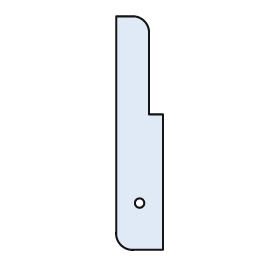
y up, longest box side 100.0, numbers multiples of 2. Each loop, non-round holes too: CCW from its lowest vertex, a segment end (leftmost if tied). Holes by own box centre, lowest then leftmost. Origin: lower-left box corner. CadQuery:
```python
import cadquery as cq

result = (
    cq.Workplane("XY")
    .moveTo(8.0, 0.0)
    .lineTo(20.0, 0.0)
    .lineTo(20.0, 58.0)
    .lineTo(14.0, 58.0)
    .lineTo(14.0, 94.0)
    .threePointArc((12.0, 98.0), (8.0, 100.0))
    .lineTo(0.0, 100.0)
    .lineTo(0.0, 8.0)
    .threePointArc((2.0, 2.0), (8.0, 0.0))
    .close()
    .moveTo(10.0, 20.0)
    .circle(2.0)
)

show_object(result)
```